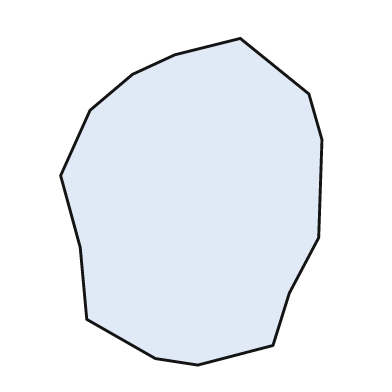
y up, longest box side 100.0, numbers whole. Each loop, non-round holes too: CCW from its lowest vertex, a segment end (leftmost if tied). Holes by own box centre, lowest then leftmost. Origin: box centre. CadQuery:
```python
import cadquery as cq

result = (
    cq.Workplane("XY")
    .moveTo(2.0, -50.0)
    .lineTo(25.0, -44.0)
    .lineTo(30.0, -28.0)
    .lineTo(39.0, -11.0)
    .lineTo(40.0, 19.0)
    .lineTo(36.0, 33.0)
    .lineTo(15.0, 50.0)
    .lineTo(-5.0, 45.0)
    .lineTo(-18.0, 39.0)
    .lineTo(-31.0, 28.0)
    .lineTo(-40.0, 8.0)
    .lineTo(-34.0, -14.0)
    .lineTo(-32.0, -36.0)
    .lineTo(-11.0, -48.0)
    .close()
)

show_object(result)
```